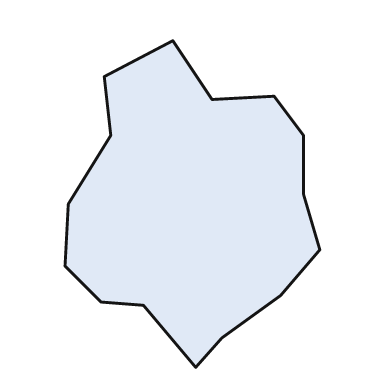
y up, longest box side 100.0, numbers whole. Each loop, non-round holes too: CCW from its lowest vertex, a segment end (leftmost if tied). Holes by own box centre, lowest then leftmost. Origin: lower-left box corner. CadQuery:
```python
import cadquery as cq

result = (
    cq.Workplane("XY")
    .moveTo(40.0, 0.0)
    .lineTo(48.0, 9.0)
    .lineTo(66.0, 22.0)
    .lineTo(78.0, 36.0)
    .lineTo(73.0, 53.0)
    .lineTo(73.0, 71.0)
    .lineTo(64.0, 83.0)
    .lineTo(45.0, 82.0)
    .lineTo(33.0, 100.0)
    .lineTo(12.0, 89.0)
    .lineTo(14.0, 71.0)
    .lineTo(1.0, 50.0)
    .lineTo(0.0, 31.0)
    .lineTo(11.0, 20.0)
    .lineTo(24.0, 19.0)
    .close()
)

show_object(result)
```